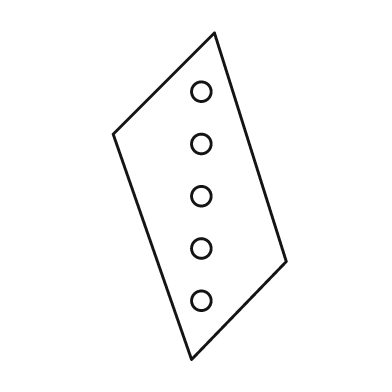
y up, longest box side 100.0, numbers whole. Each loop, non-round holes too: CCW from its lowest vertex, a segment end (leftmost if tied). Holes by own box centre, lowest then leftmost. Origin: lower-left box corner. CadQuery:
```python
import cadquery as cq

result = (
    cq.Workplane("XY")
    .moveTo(24.0, 0.0)
    .lineTo(53.0, 30.0)
    .lineTo(31.0, 100.0)
    .lineTo(0.0, 69.0)
    .close()
    .moveTo(27.0, 18.0)
    .circle(3.0)
    .moveTo(27.0, 34.0)
    .circle(3.0)
    .moveTo(27.0, 50.0)
    .circle(3.0)
    .moveTo(27.0, 66.0)
    .circle(3.0)
    .moveTo(27.0, 82.0)
    .circle(3.0)
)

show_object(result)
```